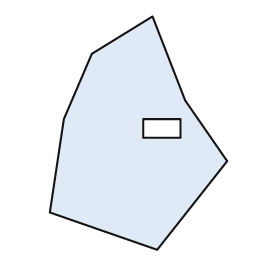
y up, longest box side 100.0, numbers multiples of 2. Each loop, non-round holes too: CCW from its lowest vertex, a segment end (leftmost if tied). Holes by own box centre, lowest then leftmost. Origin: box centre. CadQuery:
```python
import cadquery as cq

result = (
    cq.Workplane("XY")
    .moveTo(8.0, -50.0)
    .lineTo(38.0, -12.0)
    .lineTo(20.0, 14.0)
    .lineTo(6.0, 50.0)
    .lineTo(-20.0, 34.0)
    .lineTo(-32.0, 6.0)
    .lineTo(-38.0, -34.0)
    .close()
    .moveTo(2.0, -2.0)
    .lineTo(18.0, -2.0)
    .lineTo(18.0, 6.0)
    .lineTo(2.0, 6.0)
    .close()
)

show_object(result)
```